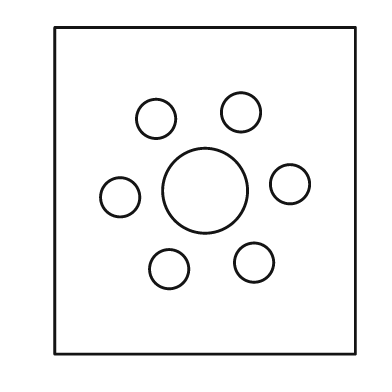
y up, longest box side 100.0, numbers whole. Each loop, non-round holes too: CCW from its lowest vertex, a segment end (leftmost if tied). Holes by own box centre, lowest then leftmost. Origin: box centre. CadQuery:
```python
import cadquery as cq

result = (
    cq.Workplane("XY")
    .moveTo(-46.0, -50.0)
    .lineTo(46.0, -50.0)
    .lineTo(46.0, 50.0)
    .lineTo(-46.0, 50.0)
    .close()
    .moveTo(-11.0, -24.0)
    .circle(6.0)
    .moveTo(15.0, -22.0)
    .circle(6.0)
    .moveTo(-26.0, -2.0)
    .circle(6.0)
    .moveTo(0.0, 0.0)
    .circle(13.0)
    .moveTo(26.0, 2.0)
    .circle(6.0)
    .moveTo(-15.0, 22.0)
    .circle(6.0)
    .moveTo(11.0, 24.0)
    .circle(6.0)
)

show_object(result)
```